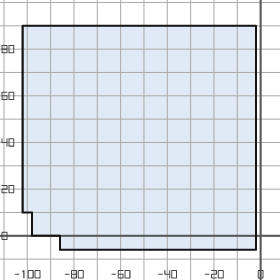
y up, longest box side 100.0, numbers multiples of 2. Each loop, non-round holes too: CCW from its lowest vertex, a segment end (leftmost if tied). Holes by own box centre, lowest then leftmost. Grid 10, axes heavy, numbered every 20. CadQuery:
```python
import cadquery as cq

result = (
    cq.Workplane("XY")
    .moveTo(-86.0, -6.0)
    .lineTo(-2.0, -6.0)
    .lineTo(-2.0, 90.0)
    .lineTo(-102.0, 90.0)
    .lineTo(-102.0, 10.0)
    .lineTo(-98.0, 10.0)
    .lineTo(-98.0, 0.0)
    .lineTo(-86.0, 0.0)
    .close()
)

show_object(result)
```